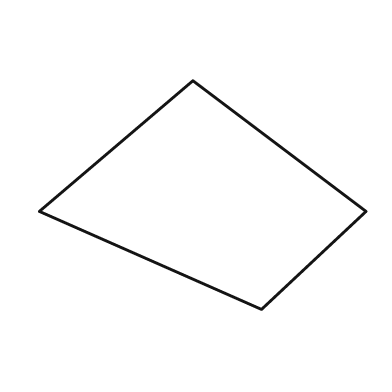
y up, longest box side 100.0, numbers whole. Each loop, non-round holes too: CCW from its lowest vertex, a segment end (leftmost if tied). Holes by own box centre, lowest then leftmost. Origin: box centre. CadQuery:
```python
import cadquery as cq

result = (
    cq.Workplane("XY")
    .moveTo(18.0, -35.0)
    .lineTo(50.0, -5.0)
    .lineTo(-3.0, 35.0)
    .lineTo(-50.0, -5.0)
    .close()
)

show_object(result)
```